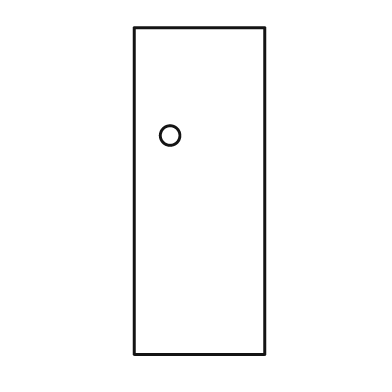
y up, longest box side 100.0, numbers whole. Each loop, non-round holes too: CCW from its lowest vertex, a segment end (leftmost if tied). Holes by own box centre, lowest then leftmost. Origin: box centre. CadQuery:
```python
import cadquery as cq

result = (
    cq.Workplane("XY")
    .moveTo(-20.0, -50.0)
    .lineTo(20.0, -50.0)
    .lineTo(20.0, 50.0)
    .lineTo(-20.0, 50.0)
    .close()
    .moveTo(-9.0, 17.0)
    .circle(3.0)
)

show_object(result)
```